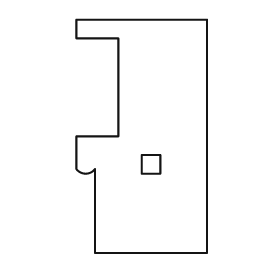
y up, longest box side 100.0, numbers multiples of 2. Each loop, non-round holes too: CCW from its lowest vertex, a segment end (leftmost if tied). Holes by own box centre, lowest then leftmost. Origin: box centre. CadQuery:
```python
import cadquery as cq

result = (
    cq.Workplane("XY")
    .moveTo(-20.0, -50.0)
    .lineTo(28.0, -50.0)
    .lineTo(28.0, 50.0)
    .lineTo(-28.0, 50.0)
    .lineTo(-28.0, 42.0)
    .lineTo(-10.0, 42.0)
    .lineTo(-10.0, 0.0)
    .lineTo(-28.0, 0.0)
    .lineTo(-28.0, -14.0)
    .threePointArc((-24.0, -16.0), (-20.0, -14.0))
    .close()
    .moveTo(0.0, -16.0)
    .lineTo(8.0, -16.0)
    .lineTo(8.0, -8.0)
    .lineTo(0.0, -8.0)
    .close()
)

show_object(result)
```